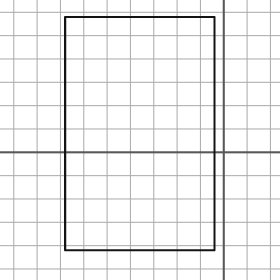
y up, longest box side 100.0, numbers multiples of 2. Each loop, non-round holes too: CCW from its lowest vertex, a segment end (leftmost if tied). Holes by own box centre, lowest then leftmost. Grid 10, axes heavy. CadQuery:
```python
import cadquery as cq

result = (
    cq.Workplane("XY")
    .moveTo(-68.0, -42.0)
    .lineTo(-4.0, -42.0)
    .lineTo(-4.0, 58.0)
    .lineTo(-68.0, 58.0)
    .close()
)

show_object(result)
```